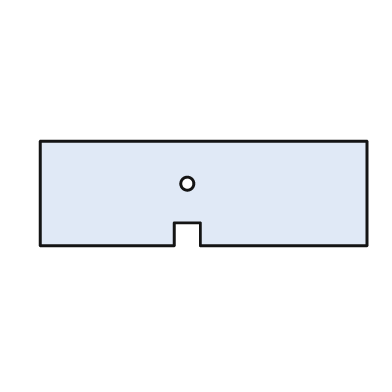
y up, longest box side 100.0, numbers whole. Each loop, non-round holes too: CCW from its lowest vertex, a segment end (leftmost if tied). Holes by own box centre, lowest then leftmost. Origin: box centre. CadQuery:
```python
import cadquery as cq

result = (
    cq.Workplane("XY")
    .moveTo(-50.0, -16.0)
    .lineTo(-9.0, -16.0)
    .lineTo(-9.0, -9.0)
    .lineTo(-1.0, -9.0)
    .lineTo(-1.0, -16.0)
    .lineTo(50.0, -16.0)
    .lineTo(50.0, 16.0)
    .lineTo(-50.0, 16.0)
    .close()
    .moveTo(-5.0, 3.0)
    .circle(2.0)
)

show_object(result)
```